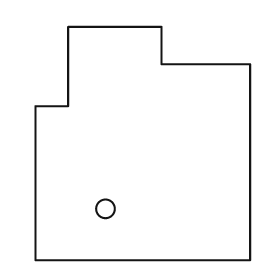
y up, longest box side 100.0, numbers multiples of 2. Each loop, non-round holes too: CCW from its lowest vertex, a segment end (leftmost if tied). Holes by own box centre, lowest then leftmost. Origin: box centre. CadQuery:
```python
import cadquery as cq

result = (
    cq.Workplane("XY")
    .moveTo(-46.0, -50.0)
    .lineTo(46.0, -50.0)
    .lineTo(46.0, 34.0)
    .lineTo(8.0, 34.0)
    .lineTo(8.0, 50.0)
    .lineTo(-32.0, 50.0)
    .lineTo(-32.0, 16.0)
    .lineTo(-46.0, 16.0)
    .close()
    .moveTo(-16.0, -28.0)
    .circle(4.0)
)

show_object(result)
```